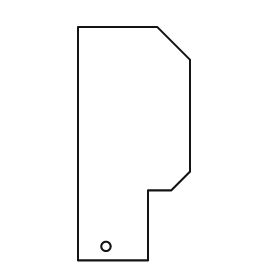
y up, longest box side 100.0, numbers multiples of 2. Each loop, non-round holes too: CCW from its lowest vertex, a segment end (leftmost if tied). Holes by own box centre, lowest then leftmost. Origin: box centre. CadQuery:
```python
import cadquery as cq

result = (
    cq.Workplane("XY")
    .moveTo(-24.0, -50.0)
    .lineTo(6.0, -50.0)
    .lineTo(6.0, -20.0)
    .lineTo(16.0, -20.0)
    .lineTo(24.0, -12.0)
    .lineTo(24.0, 36.0)
    .lineTo(10.0, 50.0)
    .lineTo(-24.0, 50.0)
    .close()
    .moveTo(-12.0, -44.0)
    .circle(2.0)
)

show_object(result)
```